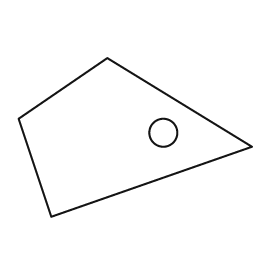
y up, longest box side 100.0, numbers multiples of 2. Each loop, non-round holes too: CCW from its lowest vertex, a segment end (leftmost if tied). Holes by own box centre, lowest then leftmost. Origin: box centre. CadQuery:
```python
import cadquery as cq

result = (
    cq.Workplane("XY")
    .moveTo(-36.0, -34.0)
    .lineTo(50.0, -4.0)
    .lineTo(-12.0, 34.0)
    .lineTo(-50.0, 8.0)
    .close()
    .moveTo(12.0, 2.0)
    .circle(6.0)
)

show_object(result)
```